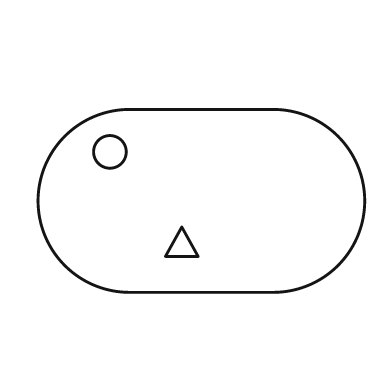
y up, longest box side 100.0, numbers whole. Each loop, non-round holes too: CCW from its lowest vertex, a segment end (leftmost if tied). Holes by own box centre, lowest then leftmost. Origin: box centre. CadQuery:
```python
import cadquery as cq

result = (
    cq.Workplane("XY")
    .moveTo(-22.0, -28.0)
    .lineTo(22.0, -28.0)
    .threePointArc((50.0, 0.0), (22.0, 28.0))
    .lineTo(-22.0, 28.0)
    .threePointArc((-50.0, 0.0), (-22.0, -28.0))
    .close()
    .moveTo(-11.0, -17.0)
    .lineTo(-1.0, -17.0)
    .lineTo(-6.0, -8.0)
    .close()
    .moveTo(-28.0, 15.0)
    .circle(5.0)
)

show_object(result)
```